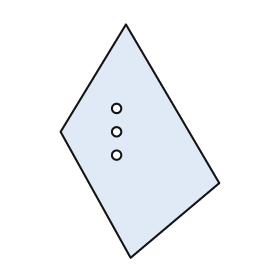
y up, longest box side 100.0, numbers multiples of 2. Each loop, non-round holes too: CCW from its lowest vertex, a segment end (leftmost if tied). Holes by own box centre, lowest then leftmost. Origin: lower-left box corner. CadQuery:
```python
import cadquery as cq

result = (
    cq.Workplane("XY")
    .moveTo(30.0, 0.0)
    .lineTo(68.0, 32.0)
    .lineTo(28.0, 100.0)
    .lineTo(0.0, 54.0)
    .close()
    .moveTo(24.0, 44.0)
    .circle(2.0)
    .moveTo(24.0, 54.0)
    .circle(2.0)
    .moveTo(24.0, 64.0)
    .circle(2.0)
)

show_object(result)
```